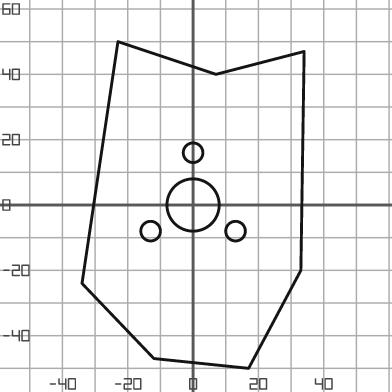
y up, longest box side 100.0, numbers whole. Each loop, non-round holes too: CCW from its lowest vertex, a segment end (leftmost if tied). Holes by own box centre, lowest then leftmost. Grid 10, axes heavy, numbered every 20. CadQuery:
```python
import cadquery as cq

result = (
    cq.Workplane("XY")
    .moveTo(17.0, -50.0)
    .lineTo(33.0, -20.0)
    .lineTo(34.0, 47.0)
    .lineTo(7.0, 40.0)
    .lineTo(-23.0, 50.0)
    .lineTo(-34.0, -24.0)
    .lineTo(-12.0, -47.0)
    .close()
    .moveTo(-13.0, -8.0)
    .circle(3.0)
    .moveTo(13.0, -8.0)
    .circle(3.0)
    .moveTo(0.0, 0.0)
    .circle(8.0)
    .moveTo(0.0, 16.0)
    .circle(3.0)
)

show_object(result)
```